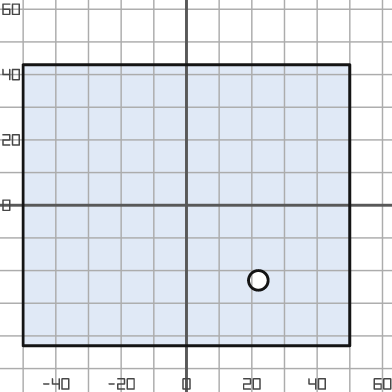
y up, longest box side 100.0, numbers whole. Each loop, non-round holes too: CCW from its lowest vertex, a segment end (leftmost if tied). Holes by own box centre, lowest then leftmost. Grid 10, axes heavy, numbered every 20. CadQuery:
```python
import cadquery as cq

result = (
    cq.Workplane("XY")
    .moveTo(-50.0, -43.0)
    .lineTo(50.0, -43.0)
    .lineTo(50.0, 43.0)
    .lineTo(-50.0, 43.0)
    .close()
    .moveTo(22.0, -23.0)
    .circle(3.0)
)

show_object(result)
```